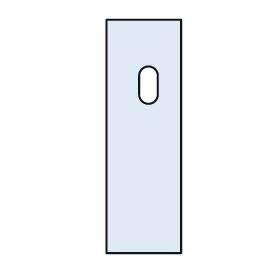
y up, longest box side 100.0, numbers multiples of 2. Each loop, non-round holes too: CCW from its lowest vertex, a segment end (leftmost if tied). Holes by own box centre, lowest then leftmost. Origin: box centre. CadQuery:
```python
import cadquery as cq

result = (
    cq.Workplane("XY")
    .moveTo(-16.0, -50.0)
    .lineTo(16.0, -50.0)
    .lineTo(16.0, 50.0)
    .lineTo(-16.0, 50.0)
    .close()
    .moveTo(-2.0, 18.0)
    .threePointArc((2.0, 14.0), (6.0, 18.0))
    .lineTo(6.0, 26.0)
    .threePointArc((2.0, 30.0), (-2.0, 26.0))
    .close()
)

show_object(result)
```